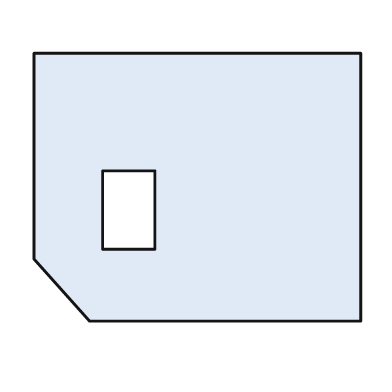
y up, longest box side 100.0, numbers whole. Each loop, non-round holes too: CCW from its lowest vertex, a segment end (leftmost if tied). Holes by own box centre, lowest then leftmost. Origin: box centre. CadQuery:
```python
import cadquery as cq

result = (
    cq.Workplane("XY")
    .moveTo(-33.0, -41.0)
    .lineTo(50.0, -41.0)
    .lineTo(50.0, 41.0)
    .lineTo(-50.0, 41.0)
    .lineTo(-50.0, -22.0)
    .close()
    .moveTo(-29.0, -19.0)
    .lineTo(-13.0, -19.0)
    .lineTo(-13.0, 5.0)
    .lineTo(-29.0, 5.0)
    .close()
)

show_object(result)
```